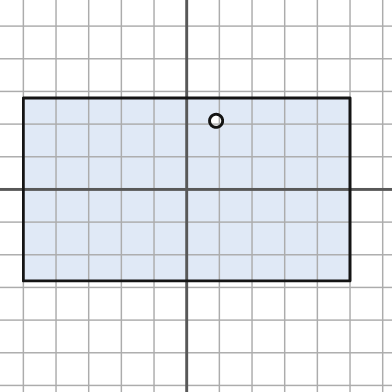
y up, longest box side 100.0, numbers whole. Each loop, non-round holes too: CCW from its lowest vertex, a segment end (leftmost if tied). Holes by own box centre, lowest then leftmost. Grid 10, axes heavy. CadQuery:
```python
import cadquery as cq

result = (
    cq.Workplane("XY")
    .moveTo(-50.0, -28.0)
    .lineTo(50.0, -28.0)
    .lineTo(50.0, 28.0)
    .lineTo(-50.0, 28.0)
    .close()
    .moveTo(9.0, 21.0)
    .circle(2.0)
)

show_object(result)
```